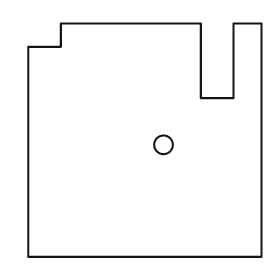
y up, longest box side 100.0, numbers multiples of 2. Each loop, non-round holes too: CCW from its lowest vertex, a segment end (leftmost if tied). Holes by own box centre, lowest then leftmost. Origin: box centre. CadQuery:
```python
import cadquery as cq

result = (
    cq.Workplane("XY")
    .moveTo(-50.0, -50.0)
    .lineTo(50.0, -50.0)
    .lineTo(50.0, 50.0)
    .lineTo(38.0, 50.0)
    .lineTo(38.0, 18.0)
    .lineTo(24.0, 18.0)
    .lineTo(24.0, 50.0)
    .lineTo(-36.0, 50.0)
    .lineTo(-36.0, 40.0)
    .lineTo(-50.0, 40.0)
    .close()
    .moveTo(8.0, -2.0)
    .circle(4.0)
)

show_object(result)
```